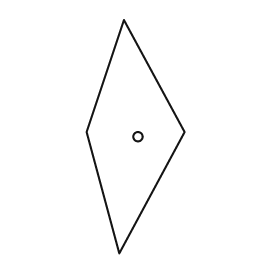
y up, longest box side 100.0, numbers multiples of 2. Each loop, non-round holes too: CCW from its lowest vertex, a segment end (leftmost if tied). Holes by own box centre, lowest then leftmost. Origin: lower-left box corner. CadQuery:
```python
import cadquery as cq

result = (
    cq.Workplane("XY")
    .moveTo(14.0, 0.0)
    .lineTo(42.0, 52.0)
    .lineTo(16.0, 100.0)
    .lineTo(0.0, 52.0)
    .close()
    .moveTo(22.0, 50.0)
    .circle(2.0)
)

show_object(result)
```